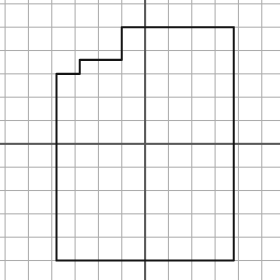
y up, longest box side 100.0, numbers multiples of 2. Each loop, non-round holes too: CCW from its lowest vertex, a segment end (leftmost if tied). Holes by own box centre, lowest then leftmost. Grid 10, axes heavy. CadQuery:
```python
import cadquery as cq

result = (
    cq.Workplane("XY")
    .moveTo(-38.0, -50.0)
    .lineTo(38.0, -50.0)
    .lineTo(38.0, 50.0)
    .lineTo(-10.0, 50.0)
    .lineTo(-10.0, 36.0)
    .lineTo(-28.0, 36.0)
    .lineTo(-28.0, 30.0)
    .lineTo(-38.0, 30.0)
    .close()
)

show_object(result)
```